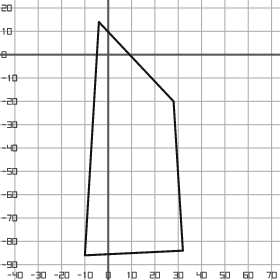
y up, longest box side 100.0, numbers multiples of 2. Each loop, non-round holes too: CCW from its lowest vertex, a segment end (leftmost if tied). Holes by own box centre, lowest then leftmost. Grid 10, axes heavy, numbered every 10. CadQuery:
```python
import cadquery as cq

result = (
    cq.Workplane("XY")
    .moveTo(-10.0, -86.0)
    .lineTo(32.0, -84.0)
    .lineTo(28.0, -20.0)
    .lineTo(-4.0, 14.0)
    .close()
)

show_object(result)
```